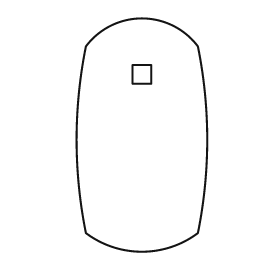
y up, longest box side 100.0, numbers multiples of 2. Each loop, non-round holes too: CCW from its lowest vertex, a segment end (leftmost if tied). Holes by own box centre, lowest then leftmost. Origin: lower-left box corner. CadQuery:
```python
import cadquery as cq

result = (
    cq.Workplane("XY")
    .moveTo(4.0, 8.0)
    .threePointArc((28.0, 0.0), (52.0, 8.0))
    .threePointArc((56.0, 48.0), (52.0, 88.0))
    .threePointArc((28.0, 100.0), (4.0, 88.0))
    .threePointArc((0.0, 48.0), (4.0, 8.0))
    .close()
    .moveTo(24.0, 72.0)
    .lineTo(32.0, 72.0)
    .lineTo(32.0, 80.0)
    .lineTo(24.0, 80.0)
    .close()
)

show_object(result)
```